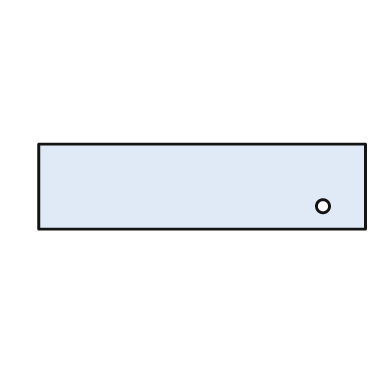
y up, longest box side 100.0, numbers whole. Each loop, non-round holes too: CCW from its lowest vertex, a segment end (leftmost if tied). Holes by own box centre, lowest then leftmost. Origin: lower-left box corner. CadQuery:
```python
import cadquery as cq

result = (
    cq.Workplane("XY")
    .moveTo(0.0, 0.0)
    .lineTo(100.0, 0.0)
    .lineTo(100.0, 26.0)
    .lineTo(0.0, 26.0)
    .close()
    .moveTo(87.0, 7.0)
    .circle(2.0)
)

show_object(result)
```